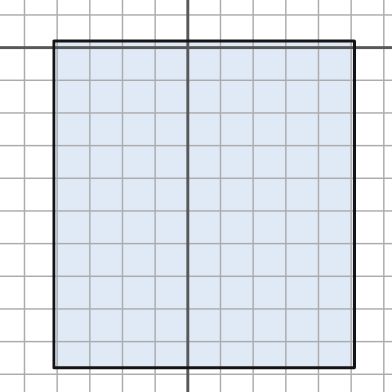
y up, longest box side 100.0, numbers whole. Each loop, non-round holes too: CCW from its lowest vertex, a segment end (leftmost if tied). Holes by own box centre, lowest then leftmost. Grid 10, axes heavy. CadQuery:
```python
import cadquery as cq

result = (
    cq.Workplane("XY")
    .moveTo(-41.0, -98.0)
    .lineTo(51.0, -98.0)
    .lineTo(51.0, 2.0)
    .lineTo(-41.0, 2.0)
    .close()
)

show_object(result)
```